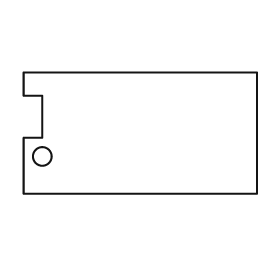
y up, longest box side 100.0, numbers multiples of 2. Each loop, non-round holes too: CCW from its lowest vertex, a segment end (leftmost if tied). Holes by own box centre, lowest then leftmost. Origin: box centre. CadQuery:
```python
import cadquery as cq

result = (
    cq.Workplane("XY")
    .moveTo(-50.0, -26.0)
    .lineTo(50.0, -26.0)
    .lineTo(50.0, 26.0)
    .lineTo(-50.0, 26.0)
    .lineTo(-50.0, 16.0)
    .lineTo(-42.0, 16.0)
    .lineTo(-42.0, -2.0)
    .lineTo(-50.0, -2.0)
    .close()
    .moveTo(-42.0, -10.0)
    .circle(4.0)
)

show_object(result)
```